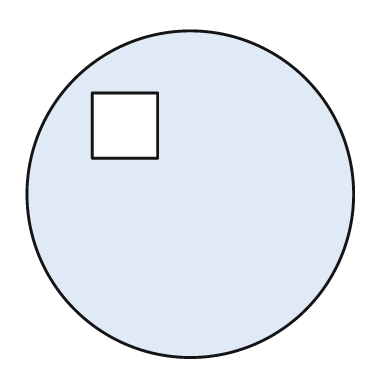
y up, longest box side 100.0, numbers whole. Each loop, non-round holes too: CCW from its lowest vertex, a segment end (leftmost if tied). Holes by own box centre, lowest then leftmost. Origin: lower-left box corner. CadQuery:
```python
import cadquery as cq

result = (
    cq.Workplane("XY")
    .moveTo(50.0, 50.0)
    .circle(50.0)
    .moveTo(20.0, 61.0)
    .lineTo(40.0, 61.0)
    .lineTo(40.0, 81.0)
    .lineTo(20.0, 81.0)
    .close()
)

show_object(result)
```